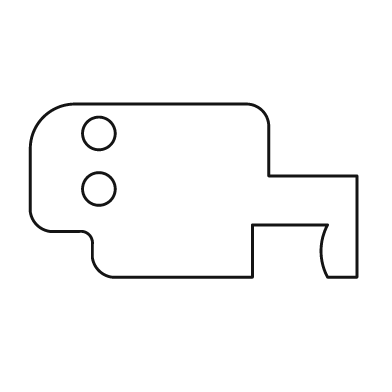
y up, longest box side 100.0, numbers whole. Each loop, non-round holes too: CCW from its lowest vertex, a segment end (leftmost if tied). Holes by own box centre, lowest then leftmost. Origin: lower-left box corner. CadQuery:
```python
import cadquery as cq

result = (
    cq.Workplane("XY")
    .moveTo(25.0, 0.0)
    .lineTo(68.0, 0.0)
    .lineTo(68.0, 16.0)
    .lineTo(91.0, 16.0)
    .threePointArc((89.0, 8.0), (91.0, 0.0))
    .lineTo(100.0, 0.0)
    .lineTo(100.0, 31.0)
    .lineTo(73.0, 31.0)
    .lineTo(73.0, 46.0)
    .threePointArc((71.0, 51.0), (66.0, 53.0))
    .lineTo(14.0, 53.0)
    .threePointArc((4.0, 49.0), (0.0, 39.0))
    .lineTo(0.0, 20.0)
    .threePointArc((2.0, 16.0), (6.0, 14.0))
    .lineTo(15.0, 14.0)
    .threePointArc((18.0, 13.0), (19.0, 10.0))
    .lineTo(19.0, 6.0)
    .threePointArc((21.0, 2.0), (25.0, 0.0))
    .close()
    .moveTo(21.0, 27.0)
    .circle(5.0)
    .moveTo(21.0, 44.0)
    .circle(5.0)
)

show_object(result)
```